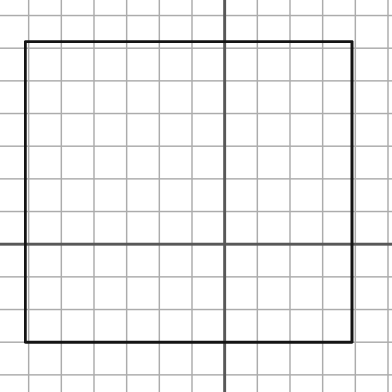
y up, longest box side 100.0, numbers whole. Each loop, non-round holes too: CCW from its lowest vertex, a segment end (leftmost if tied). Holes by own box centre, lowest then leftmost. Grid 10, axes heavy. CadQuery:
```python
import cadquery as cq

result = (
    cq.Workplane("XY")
    .moveTo(-61.0, -30.0)
    .lineTo(39.0, -30.0)
    .lineTo(39.0, 62.0)
    .lineTo(-61.0, 62.0)
    .close()
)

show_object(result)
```